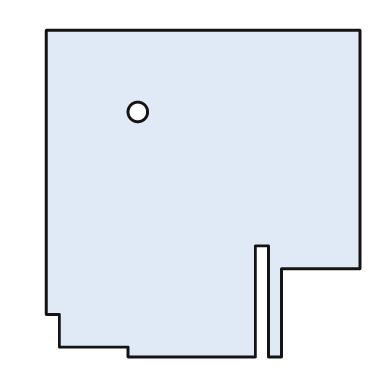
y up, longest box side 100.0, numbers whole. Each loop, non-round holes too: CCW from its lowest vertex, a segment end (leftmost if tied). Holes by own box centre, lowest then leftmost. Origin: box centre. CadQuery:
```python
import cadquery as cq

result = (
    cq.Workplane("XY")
    .moveTo(-23.0, -50.0)
    .lineTo(16.0, -50.0)
    .lineTo(16.0, -16.0)
    .lineTo(20.0, -16.0)
    .lineTo(20.0, -50.0)
    .lineTo(24.0, -50.0)
    .lineTo(24.0, -23.0)
    .lineTo(48.0, -23.0)
    .lineTo(48.0, 50.0)
    .lineTo(-48.0, 50.0)
    .lineTo(-48.0, -37.0)
    .lineTo(-44.0, -37.0)
    .lineTo(-44.0, -47.0)
    .lineTo(-23.0, -47.0)
    .close()
    .moveTo(-20.0, 25.0)
    .circle(3.0)
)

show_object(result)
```